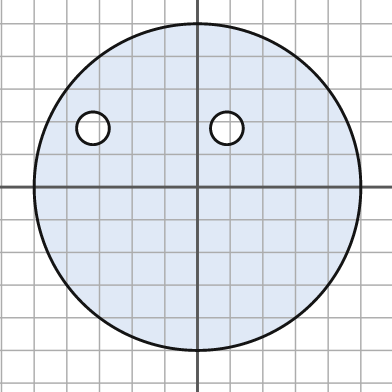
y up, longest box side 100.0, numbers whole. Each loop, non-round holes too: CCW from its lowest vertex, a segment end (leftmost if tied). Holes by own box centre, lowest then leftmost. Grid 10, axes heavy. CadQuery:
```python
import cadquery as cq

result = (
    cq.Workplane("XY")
    .moveTo(0.0, 0.0)
    .circle(50.0)
    .moveTo(-32.0, 18.0)
    .circle(5.0)
    .moveTo(9.0, 18.0)
    .circle(5.0)
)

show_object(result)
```